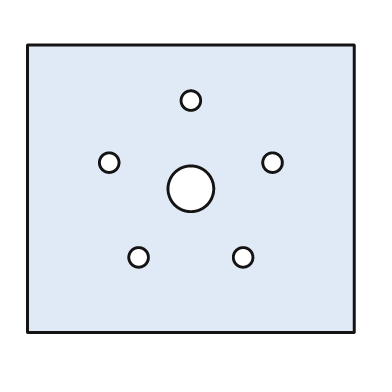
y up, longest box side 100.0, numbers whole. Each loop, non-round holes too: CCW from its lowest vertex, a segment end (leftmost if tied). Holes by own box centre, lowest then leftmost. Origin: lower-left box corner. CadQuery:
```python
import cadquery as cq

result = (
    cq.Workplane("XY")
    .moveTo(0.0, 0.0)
    .lineTo(100.0, 0.0)
    .lineTo(100.0, 88.0)
    .lineTo(0.0, 88.0)
    .close()
    .moveTo(34.0, 23.0)
    .circle(3.0)
    .moveTo(66.0, 23.0)
    .circle(3.0)
    .moveTo(50.0, 44.0)
    .circle(7.0)
    .moveTo(25.0, 52.0)
    .circle(3.0)
    .moveTo(75.0, 52.0)
    .circle(3.0)
    .moveTo(50.0, 71.0)
    .circle(3.0)
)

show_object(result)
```